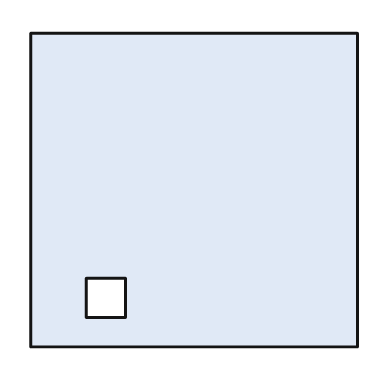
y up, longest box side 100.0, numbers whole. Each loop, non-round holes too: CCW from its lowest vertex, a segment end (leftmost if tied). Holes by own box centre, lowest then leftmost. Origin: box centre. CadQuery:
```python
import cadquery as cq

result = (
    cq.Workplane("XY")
    .moveTo(-50.0, -48.0)
    .lineTo(50.0, -48.0)
    .lineTo(50.0, 48.0)
    .lineTo(-50.0, 48.0)
    .close()
    .moveTo(-33.0, -39.0)
    .lineTo(-21.0, -39.0)
    .lineTo(-21.0, -27.0)
    .lineTo(-33.0, -27.0)
    .close()
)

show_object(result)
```